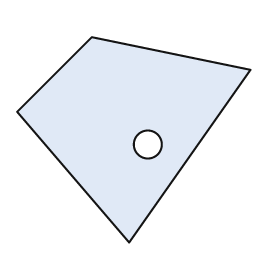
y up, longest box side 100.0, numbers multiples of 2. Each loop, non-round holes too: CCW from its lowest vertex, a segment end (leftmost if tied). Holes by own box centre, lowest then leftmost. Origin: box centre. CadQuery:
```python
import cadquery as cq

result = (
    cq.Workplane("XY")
    .moveTo(-2.0, -44.0)
    .lineTo(50.0, 30.0)
    .lineTo(-18.0, 44.0)
    .lineTo(-50.0, 12.0)
    .close()
    .moveTo(6.0, -2.0)
    .circle(6.0)
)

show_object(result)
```